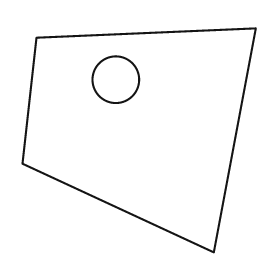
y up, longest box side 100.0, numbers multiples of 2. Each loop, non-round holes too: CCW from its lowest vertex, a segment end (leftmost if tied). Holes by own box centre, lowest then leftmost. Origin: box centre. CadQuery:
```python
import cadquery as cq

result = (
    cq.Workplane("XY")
    .moveTo(32.0, -48.0)
    .lineTo(50.0, 48.0)
    .lineTo(-44.0, 44.0)
    .lineTo(-50.0, -10.0)
    .close()
    .moveTo(-10.0, 26.0)
    .circle(10.0)
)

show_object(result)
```